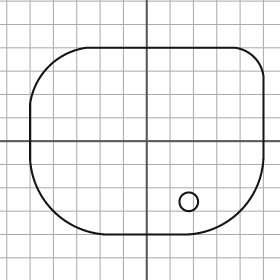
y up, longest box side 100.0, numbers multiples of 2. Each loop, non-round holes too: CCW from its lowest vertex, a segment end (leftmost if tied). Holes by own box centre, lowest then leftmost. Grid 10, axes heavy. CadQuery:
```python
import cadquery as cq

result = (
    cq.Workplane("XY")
    .moveTo(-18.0, -40.0)
    .lineTo(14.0, -40.0)
    .threePointArc((40.0, -30.0), (50.0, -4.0))
    .lineTo(50.0, 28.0)
    .threePointArc((46.0, 36.0), (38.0, 40.0))
    .lineTo(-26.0, 40.0)
    .threePointArc((-42.0, 32.0), (-50.0, 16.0))
    .lineTo(-50.0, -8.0)
    .threePointArc((-40.0, -30.0), (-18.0, -40.0))
    .close()
    .moveTo(18.0, -26.0)
    .circle(4.0)
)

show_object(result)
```